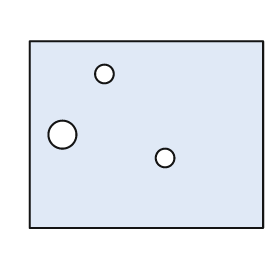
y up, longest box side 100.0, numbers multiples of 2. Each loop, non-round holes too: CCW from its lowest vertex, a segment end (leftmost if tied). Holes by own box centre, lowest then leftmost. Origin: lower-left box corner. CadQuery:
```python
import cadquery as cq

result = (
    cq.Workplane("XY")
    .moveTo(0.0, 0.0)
    .lineTo(100.0, 0.0)
    .lineTo(100.0, 80.0)
    .lineTo(0.0, 80.0)
    .close()
    .moveTo(58.0, 30.0)
    .circle(4.0)
    .moveTo(14.0, 40.0)
    .circle(6.0)
    .moveTo(32.0, 66.0)
    .circle(4.0)
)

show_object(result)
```